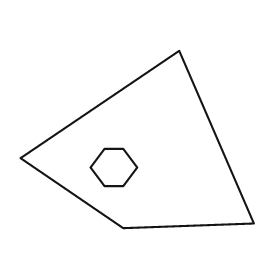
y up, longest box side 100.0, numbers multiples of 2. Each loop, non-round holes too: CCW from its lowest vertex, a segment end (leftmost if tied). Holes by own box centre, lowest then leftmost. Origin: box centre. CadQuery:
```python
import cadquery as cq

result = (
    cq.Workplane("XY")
    .moveTo(-6.0, -38.0)
    .lineTo(50.0, -36.0)
    .lineTo(18.0, 38.0)
    .lineTo(-50.0, -8.0)
    .close()
    .moveTo(-14.0, -20.0)
    .lineTo(-6.0, -20.0)
    .lineTo(0.0, -12.0)
    .lineTo(-6.0, -4.0)
    .lineTo(-14.0, -4.0)
    .lineTo(-20.0, -12.0)
    .close()
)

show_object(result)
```